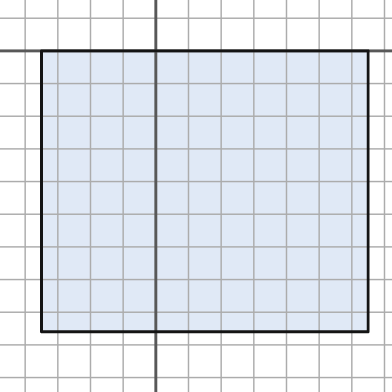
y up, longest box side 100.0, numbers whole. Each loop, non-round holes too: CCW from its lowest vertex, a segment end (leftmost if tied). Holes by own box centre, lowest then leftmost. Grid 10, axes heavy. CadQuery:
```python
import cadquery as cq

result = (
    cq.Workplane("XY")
    .moveTo(-35.0, -86.0)
    .lineTo(65.0, -86.0)
    .lineTo(65.0, 0.0)
    .lineTo(-35.0, 0.0)
    .close()
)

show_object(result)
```